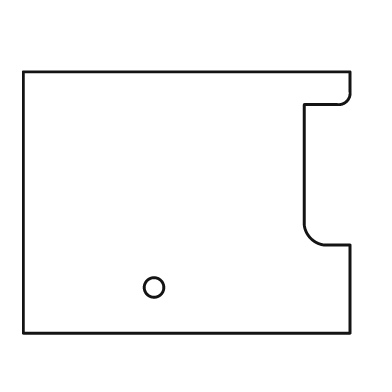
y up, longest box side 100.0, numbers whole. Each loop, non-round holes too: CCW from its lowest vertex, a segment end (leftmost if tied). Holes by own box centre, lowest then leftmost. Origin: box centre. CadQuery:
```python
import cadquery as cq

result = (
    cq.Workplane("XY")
    .moveTo(-50.0, -40.0)
    .lineTo(50.0, -40.0)
    .lineTo(50.0, -13.0)
    .lineTo(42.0, -13.0)
    .threePointArc((38.0, -11.0), (36.0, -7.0))
    .lineTo(36.0, 30.0)
    .lineTo(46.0, 30.0)
    .threePointArc((49.0, 31.0), (50.0, 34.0))
    .lineTo(50.0, 40.0)
    .lineTo(-50.0, 40.0)
    .close()
    .moveTo(-10.0, -26.0)
    .circle(3.0)
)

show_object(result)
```